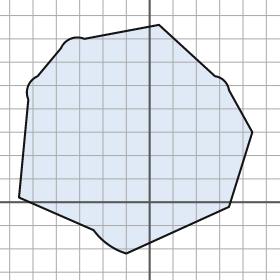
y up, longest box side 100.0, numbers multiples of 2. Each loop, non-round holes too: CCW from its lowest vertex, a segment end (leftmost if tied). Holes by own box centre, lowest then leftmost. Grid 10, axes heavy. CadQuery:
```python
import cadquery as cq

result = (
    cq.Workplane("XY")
    .moveTo(-10.0, -22.0)
    .lineTo(34.0, -2.0)
    .lineTo(44.0, 30.0)
    .lineTo(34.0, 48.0)
    .threePointArc((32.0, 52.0), (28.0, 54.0))
    .lineTo(4.0, 76.0)
    .lineTo(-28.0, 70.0)
    .threePointArc((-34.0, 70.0), (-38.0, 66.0))
    .lineTo(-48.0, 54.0)
    .threePointArc((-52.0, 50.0), (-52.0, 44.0))
    .lineTo(-56.0, 2.0)
    .lineTo(-24.0, -12.0)
    .threePointArc((-18.0, -18.0), (-10.0, -22.0))
    .close()
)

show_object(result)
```